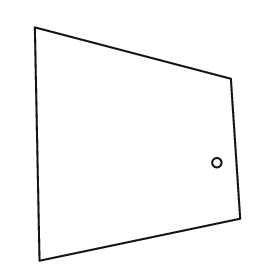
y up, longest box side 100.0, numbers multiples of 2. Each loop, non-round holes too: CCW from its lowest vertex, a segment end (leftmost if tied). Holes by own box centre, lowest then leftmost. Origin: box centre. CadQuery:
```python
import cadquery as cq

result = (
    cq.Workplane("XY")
    .moveTo(-42.0, -50.0)
    .lineTo(44.0, -32.0)
    .lineTo(40.0, 28.0)
    .lineTo(-44.0, 50.0)
    .close()
    .moveTo(34.0, -8.0)
    .circle(2.0)
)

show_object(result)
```